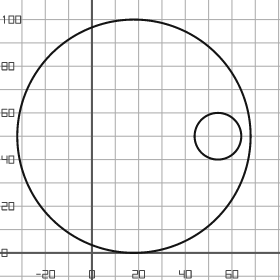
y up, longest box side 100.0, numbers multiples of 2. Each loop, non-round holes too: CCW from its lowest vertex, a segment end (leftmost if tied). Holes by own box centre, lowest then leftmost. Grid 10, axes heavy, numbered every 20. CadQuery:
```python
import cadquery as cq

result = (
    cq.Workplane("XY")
    .moveTo(18.0, 50.0)
    .circle(50.0)
    .moveTo(54.0, 50.0)
    .circle(10.0)
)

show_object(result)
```